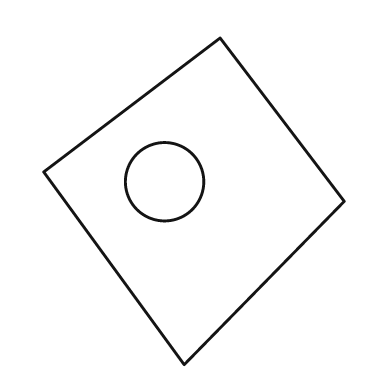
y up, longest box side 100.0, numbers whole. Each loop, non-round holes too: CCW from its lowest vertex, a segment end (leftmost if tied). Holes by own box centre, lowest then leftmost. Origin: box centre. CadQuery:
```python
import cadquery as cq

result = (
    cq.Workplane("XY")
    .moveTo(-3.0, -50.0)
    .lineTo(46.0, 0.0)
    .lineTo(8.0, 50.0)
    .lineTo(-46.0, 9.0)
    .close()
    .moveTo(-9.0, 6.0)
    .circle(12.0)
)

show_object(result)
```